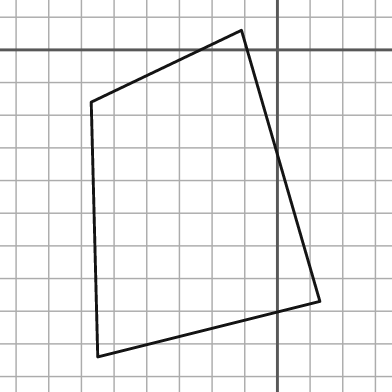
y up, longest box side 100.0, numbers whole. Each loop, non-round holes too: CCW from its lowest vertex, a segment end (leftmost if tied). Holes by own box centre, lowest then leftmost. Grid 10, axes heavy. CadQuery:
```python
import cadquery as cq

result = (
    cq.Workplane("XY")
    .moveTo(-55.0, -94.0)
    .lineTo(13.0, -77.0)
    .lineTo(-11.0, 6.0)
    .lineTo(-57.0, -16.0)
    .close()
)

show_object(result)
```